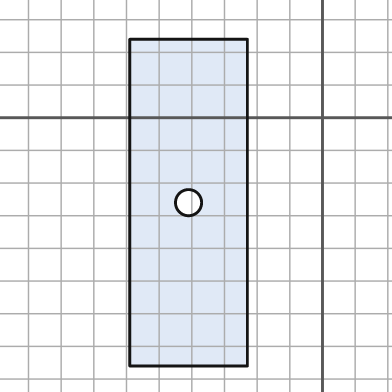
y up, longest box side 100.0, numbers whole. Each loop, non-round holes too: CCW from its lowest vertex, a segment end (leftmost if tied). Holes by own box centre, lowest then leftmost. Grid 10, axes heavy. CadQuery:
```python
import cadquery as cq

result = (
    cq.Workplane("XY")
    .moveTo(-59.0, -76.0)
    .lineTo(-23.0, -76.0)
    .lineTo(-23.0, 24.0)
    .lineTo(-59.0, 24.0)
    .close()
    .moveTo(-41.0, -26.0)
    .circle(4.0)
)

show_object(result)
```